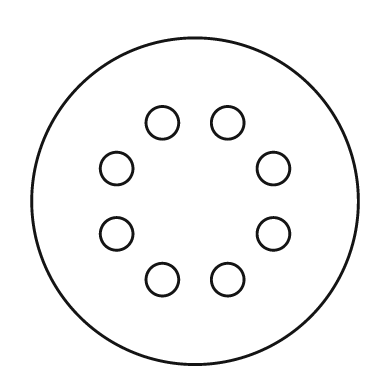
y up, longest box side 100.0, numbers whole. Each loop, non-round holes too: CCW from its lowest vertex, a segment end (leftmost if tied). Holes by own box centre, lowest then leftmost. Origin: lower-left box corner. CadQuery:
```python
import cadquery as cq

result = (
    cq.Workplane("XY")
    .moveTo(50.0, 50.0)
    .circle(50.0)
    .moveTo(40.0, 26.0)
    .circle(5.0)
    .moveTo(60.0, 26.0)
    .circle(5.0)
    .moveTo(26.0, 40.0)
    .circle(5.0)
    .moveTo(74.0, 40.0)
    .circle(5.0)
    .moveTo(26.0, 60.0)
    .circle(5.0)
    .moveTo(74.0, 60.0)
    .circle(5.0)
    .moveTo(40.0, 74.0)
    .circle(5.0)
    .moveTo(60.0, 74.0)
    .circle(5.0)
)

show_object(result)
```